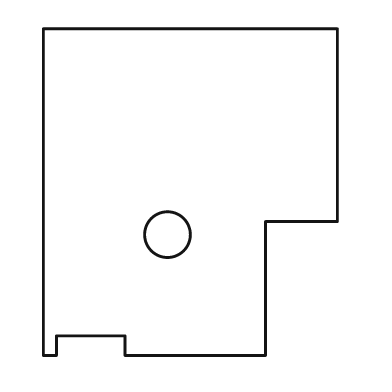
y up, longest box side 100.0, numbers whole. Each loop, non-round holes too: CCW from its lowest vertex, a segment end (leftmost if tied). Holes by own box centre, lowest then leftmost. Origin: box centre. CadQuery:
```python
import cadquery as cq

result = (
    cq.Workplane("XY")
    .moveTo(-45.0, -50.0)
    .lineTo(-41.0, -50.0)
    .lineTo(-41.0, -44.0)
    .lineTo(-20.0, -44.0)
    .lineTo(-20.0, -50.0)
    .lineTo(23.0, -50.0)
    .lineTo(23.0, -9.0)
    .lineTo(45.0, -9.0)
    .lineTo(45.0, 50.0)
    .lineTo(-45.0, 50.0)
    .close()
    .moveTo(-7.0, -13.0)
    .circle(7.0)
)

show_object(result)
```